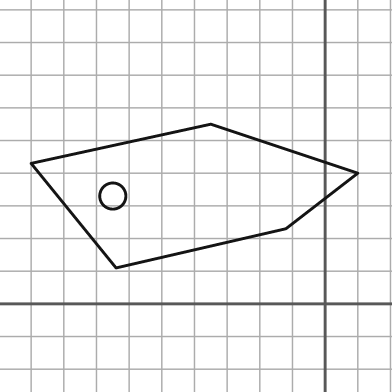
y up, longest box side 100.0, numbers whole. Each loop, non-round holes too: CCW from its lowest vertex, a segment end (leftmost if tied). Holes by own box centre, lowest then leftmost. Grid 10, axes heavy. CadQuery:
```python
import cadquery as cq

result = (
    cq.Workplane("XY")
    .moveTo(-64.0, 11.0)
    .lineTo(-12.0, 23.0)
    .lineTo(10.0, 40.0)
    .lineTo(-35.0, 55.0)
    .lineTo(-90.0, 43.0)
    .close()
    .moveTo(-65.0, 33.0)
    .circle(4.0)
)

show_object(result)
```